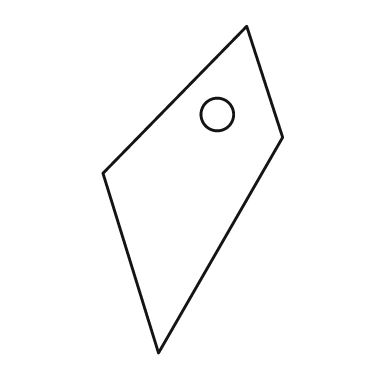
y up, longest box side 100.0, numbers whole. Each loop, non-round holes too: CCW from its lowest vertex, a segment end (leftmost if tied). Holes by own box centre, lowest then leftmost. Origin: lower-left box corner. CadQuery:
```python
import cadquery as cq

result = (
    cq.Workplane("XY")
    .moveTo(17.0, 0.0)
    .lineTo(55.0, 66.0)
    .lineTo(44.0, 100.0)
    .lineTo(0.0, 55.0)
    .close()
    .moveTo(35.0, 73.0)
    .circle(5.0)
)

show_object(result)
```